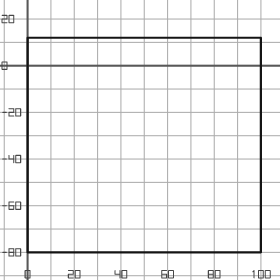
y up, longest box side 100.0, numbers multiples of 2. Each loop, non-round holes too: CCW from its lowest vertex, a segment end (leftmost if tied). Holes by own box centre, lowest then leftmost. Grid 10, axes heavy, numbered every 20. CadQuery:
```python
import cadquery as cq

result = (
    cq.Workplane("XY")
    .moveTo(0.0, -80.0)
    .lineTo(100.0, -80.0)
    .lineTo(100.0, 12.0)
    .lineTo(0.0, 12.0)
    .close()
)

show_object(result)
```